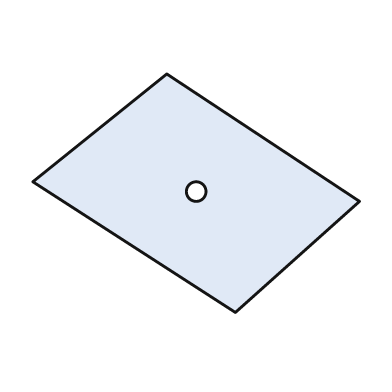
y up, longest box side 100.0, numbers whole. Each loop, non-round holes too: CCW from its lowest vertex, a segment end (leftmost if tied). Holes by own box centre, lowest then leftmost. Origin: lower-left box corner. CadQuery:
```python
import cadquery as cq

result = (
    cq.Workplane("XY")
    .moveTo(62.0, 0.0)
    .lineTo(100.0, 34.0)
    .lineTo(41.0, 73.0)
    .lineTo(0.0, 40.0)
    .close()
    .moveTo(50.0, 37.0)
    .circle(3.0)
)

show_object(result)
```